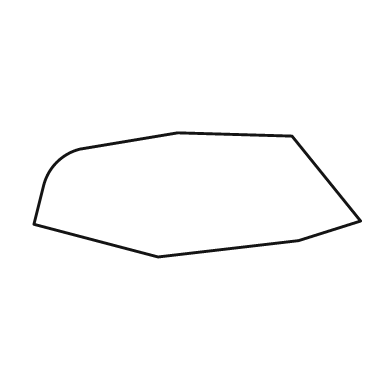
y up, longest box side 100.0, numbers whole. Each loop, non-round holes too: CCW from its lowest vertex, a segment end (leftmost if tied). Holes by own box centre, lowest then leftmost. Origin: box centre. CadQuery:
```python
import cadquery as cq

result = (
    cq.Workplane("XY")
    .moveTo(-12.0, -19.0)
    .lineTo(31.0, -14.0)
    .lineTo(50.0, -8.0)
    .lineTo(29.0, 18.0)
    .lineTo(-6.0, 19.0)
    .lineTo(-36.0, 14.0)
    .threePointArc((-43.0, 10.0), (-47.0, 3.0))
    .lineTo(-50.0, -9.0)
    .close()
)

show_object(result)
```